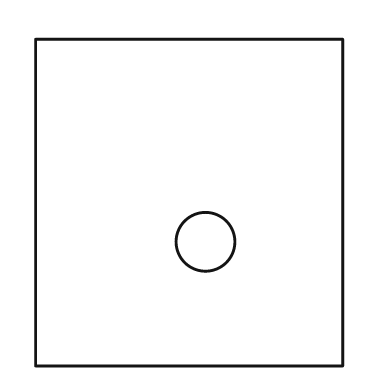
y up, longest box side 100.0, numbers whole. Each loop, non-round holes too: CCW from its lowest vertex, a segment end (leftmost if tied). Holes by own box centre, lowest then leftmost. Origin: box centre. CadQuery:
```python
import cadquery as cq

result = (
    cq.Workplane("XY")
    .moveTo(-47.0, -50.0)
    .lineTo(47.0, -50.0)
    .lineTo(47.0, 50.0)
    .lineTo(-47.0, 50.0)
    .close()
    .moveTo(5.0, -12.0)
    .circle(9.0)
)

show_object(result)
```